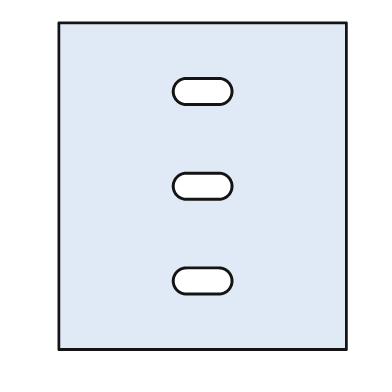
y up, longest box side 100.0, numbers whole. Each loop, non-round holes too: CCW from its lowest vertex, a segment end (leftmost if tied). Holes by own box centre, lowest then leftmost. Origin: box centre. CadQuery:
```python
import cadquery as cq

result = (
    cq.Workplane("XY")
    .moveTo(-44.0, -50.0)
    .lineTo(44.0, -50.0)
    .lineTo(44.0, 50.0)
    .lineTo(-44.0, 50.0)
    .close()
    .moveTo(-5.0, -33.0)
    .lineTo(5.0, -33.0)
    .threePointArc((9.0, -29.0), (5.0, -25.0))
    .lineTo(-5.0, -25.0)
    .threePointArc((-9.0, -29.0), (-5.0, -33.0))
    .close()
    .moveTo(-5.0, -4.0)
    .lineTo(5.0, -4.0)
    .threePointArc((9.0, 0.0), (5.0, 4.0))
    .lineTo(-5.0, 4.0)
    .threePointArc((-9.0, 0.0), (-5.0, -4.0))
    .close()
    .moveTo(-5.0, 25.0)
    .lineTo(5.0, 25.0)
    .threePointArc((9.0, 29.0), (5.0, 33.0))
    .lineTo(-5.0, 33.0)
    .threePointArc((-9.0, 29.0), (-5.0, 25.0))
    .close()
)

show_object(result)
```